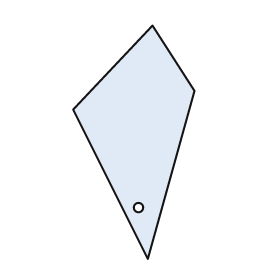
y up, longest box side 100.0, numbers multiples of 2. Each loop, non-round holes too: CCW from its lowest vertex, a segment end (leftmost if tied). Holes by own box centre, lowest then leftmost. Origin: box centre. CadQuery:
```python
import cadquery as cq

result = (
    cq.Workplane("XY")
    .moveTo(6.0, -50.0)
    .lineTo(26.0, 22.0)
    .lineTo(8.0, 50.0)
    .lineTo(-26.0, 14.0)
    .close()
    .moveTo(2.0, -28.0)
    .circle(2.0)
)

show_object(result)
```